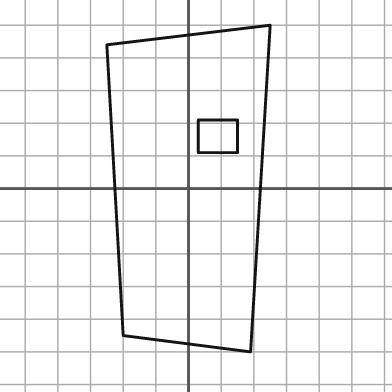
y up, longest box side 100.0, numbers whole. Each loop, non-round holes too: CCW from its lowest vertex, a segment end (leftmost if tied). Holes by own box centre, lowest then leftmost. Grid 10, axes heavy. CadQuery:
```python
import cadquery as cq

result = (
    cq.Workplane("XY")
    .moveTo(19.0, -50.0)
    .lineTo(25.0, 50.0)
    .lineTo(-25.0, 44.0)
    .lineTo(-20.0, -45.0)
    .close()
    .moveTo(3.0, 11.0)
    .lineTo(15.0, 11.0)
    .lineTo(15.0, 21.0)
    .lineTo(3.0, 21.0)
    .close()
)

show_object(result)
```